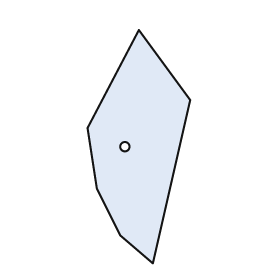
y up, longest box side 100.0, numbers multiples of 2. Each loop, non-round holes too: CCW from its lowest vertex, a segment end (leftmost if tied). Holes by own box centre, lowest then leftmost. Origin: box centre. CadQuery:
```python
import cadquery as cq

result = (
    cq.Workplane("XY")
    .moveTo(6.0, -50.0)
    .lineTo(22.0, 20.0)
    .lineTo(0.0, 50.0)
    .lineTo(-22.0, 8.0)
    .lineTo(-18.0, -18.0)
    .lineTo(-8.0, -38.0)
    .close()
    .moveTo(-6.0, 0.0)
    .circle(2.0)
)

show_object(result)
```